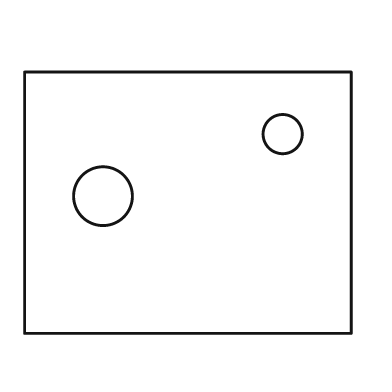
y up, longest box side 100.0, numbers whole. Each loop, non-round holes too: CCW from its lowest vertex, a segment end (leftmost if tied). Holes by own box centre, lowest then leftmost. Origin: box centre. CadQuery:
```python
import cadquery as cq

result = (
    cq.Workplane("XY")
    .moveTo(-50.0, -40.0)
    .lineTo(50.0, -40.0)
    .lineTo(50.0, 40.0)
    .lineTo(-50.0, 40.0)
    .close()
    .moveTo(-26.0, 2.0)
    .circle(9.0)
    .moveTo(29.0, 21.0)
    .circle(6.0)
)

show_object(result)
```